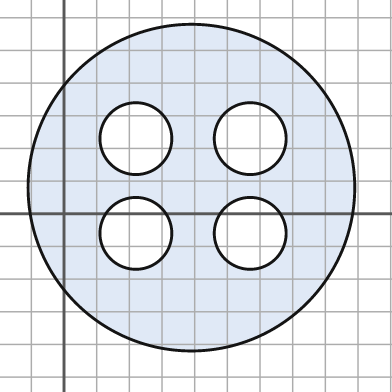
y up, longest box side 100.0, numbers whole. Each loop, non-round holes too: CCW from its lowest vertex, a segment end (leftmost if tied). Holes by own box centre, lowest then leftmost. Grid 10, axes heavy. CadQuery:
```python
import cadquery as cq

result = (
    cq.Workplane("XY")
    .moveTo(39.0, 8.0)
    .circle(50.0)
    .moveTo(22.0, -6.0)
    .circle(11.0)
    .moveTo(57.0, -6.0)
    .circle(11.0)
    .moveTo(22.0, 23.0)
    .circle(11.0)
    .moveTo(57.0, 23.0)
    .circle(11.0)
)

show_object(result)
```